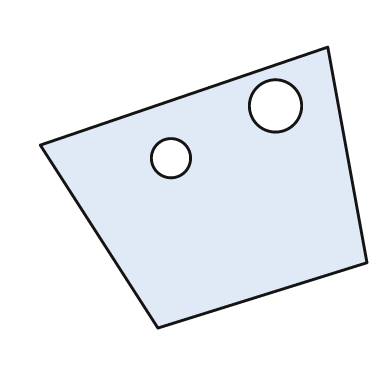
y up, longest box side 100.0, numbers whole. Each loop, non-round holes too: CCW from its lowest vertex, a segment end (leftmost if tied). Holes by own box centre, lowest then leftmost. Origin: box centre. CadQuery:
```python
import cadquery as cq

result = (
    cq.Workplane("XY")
    .moveTo(-14.0, -43.0)
    .lineTo(50.0, -23.0)
    .lineTo(38.0, 43.0)
    .lineTo(-50.0, 13.0)
    .close()
    .moveTo(-10.0, 9.0)
    .circle(6.0)
    .moveTo(22.0, 25.0)
    .circle(8.0)
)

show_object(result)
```